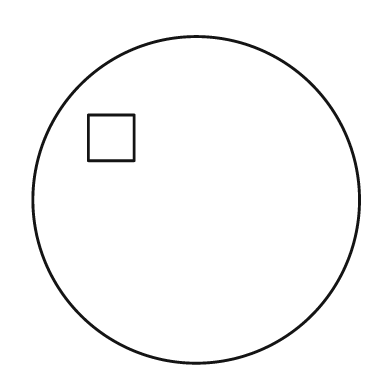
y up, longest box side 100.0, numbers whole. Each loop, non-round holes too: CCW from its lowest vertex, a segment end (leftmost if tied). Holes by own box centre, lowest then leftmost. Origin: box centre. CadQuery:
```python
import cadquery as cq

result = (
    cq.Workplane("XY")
    .moveTo(0.0, 0.0)
    .circle(50.0)
    .moveTo(-33.0, 12.0)
    .lineTo(-19.0, 12.0)
    .lineTo(-19.0, 26.0)
    .lineTo(-33.0, 26.0)
    .close()
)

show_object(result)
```